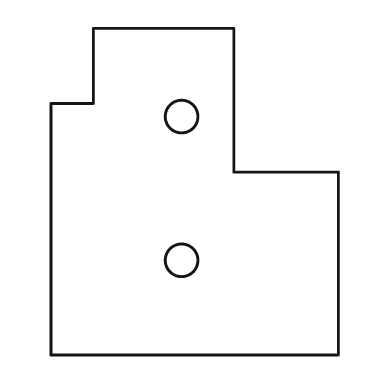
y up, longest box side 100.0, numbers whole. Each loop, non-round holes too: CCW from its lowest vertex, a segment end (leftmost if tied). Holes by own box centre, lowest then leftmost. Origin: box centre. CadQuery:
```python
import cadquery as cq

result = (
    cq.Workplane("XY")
    .moveTo(-44.0, -50.0)
    .lineTo(44.0, -50.0)
    .lineTo(44.0, 6.0)
    .lineTo(12.0, 6.0)
    .lineTo(12.0, 50.0)
    .lineTo(-31.0, 50.0)
    .lineTo(-31.0, 27.0)
    .lineTo(-44.0, 27.0)
    .close()
    .moveTo(-4.0, -21.0)
    .circle(5.0)
    .moveTo(-4.0, 23.0)
    .circle(5.0)
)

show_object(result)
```